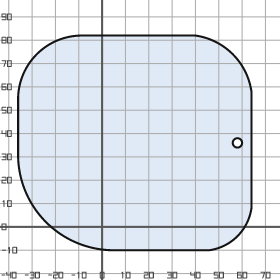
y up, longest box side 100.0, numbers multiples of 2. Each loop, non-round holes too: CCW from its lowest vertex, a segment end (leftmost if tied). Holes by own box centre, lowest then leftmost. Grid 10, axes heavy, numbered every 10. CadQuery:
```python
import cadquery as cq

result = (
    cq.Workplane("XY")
    .moveTo(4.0, -10.0)
    .lineTo(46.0, -10.0)
    .threePointArc((58.0, -4.0), (64.0, 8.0))
    .lineTo(64.0, 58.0)
    .threePointArc((56.0, 74.0), (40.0, 82.0))
    .lineTo(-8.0, 82.0)
    .threePointArc((-28.0, 74.0), (-36.0, 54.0))
    .lineTo(-36.0, 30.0)
    .threePointArc((-24.0, 2.0), (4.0, -10.0))
    .close()
    .moveTo(58.0, 36.0)
    .circle(2.0)
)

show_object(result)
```